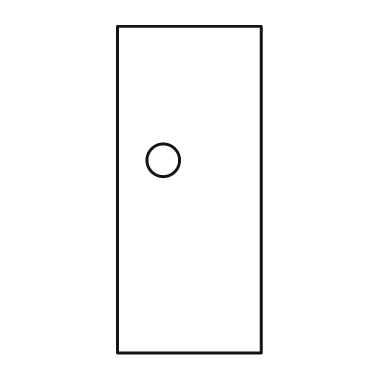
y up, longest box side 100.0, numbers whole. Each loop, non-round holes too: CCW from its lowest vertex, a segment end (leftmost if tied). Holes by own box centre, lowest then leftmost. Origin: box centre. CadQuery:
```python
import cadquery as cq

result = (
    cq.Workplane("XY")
    .moveTo(-22.0, -50.0)
    .lineTo(22.0, -50.0)
    .lineTo(22.0, 50.0)
    .lineTo(-22.0, 50.0)
    .close()
    .moveTo(-8.0, 9.0)
    .circle(5.0)
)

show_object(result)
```